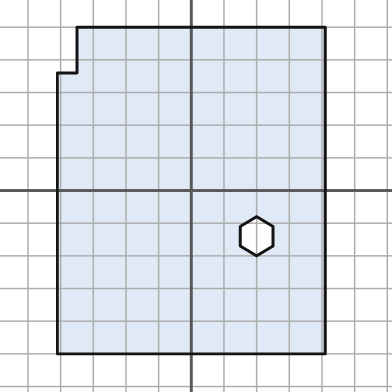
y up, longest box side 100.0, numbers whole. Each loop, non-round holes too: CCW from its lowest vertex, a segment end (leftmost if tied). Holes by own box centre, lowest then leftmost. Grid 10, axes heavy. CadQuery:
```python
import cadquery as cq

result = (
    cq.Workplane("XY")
    .moveTo(-41.0, -50.0)
    .lineTo(41.0, -50.0)
    .lineTo(41.0, 50.0)
    .lineTo(-35.0, 50.0)
    .lineTo(-35.0, 36.0)
    .lineTo(-41.0, 36.0)
    .close()
    .moveTo(20.0, -20.0)
    .lineTo(25.0, -17.0)
    .lineTo(25.0, -11.0)
    .lineTo(20.0, -8.0)
    .lineTo(15.0, -11.0)
    .lineTo(15.0, -17.0)
    .close()
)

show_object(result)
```